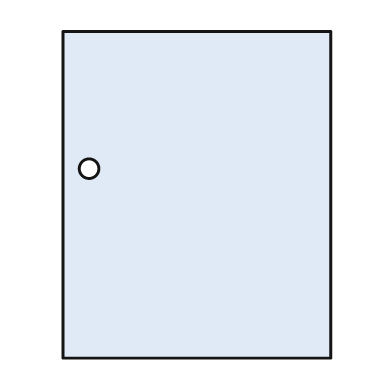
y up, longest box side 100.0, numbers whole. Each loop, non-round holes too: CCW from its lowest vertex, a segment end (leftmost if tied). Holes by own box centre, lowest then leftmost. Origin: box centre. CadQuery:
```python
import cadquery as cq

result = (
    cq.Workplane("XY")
    .moveTo(-41.0, -50.0)
    .lineTo(41.0, -50.0)
    .lineTo(41.0, 50.0)
    .lineTo(-41.0, 50.0)
    .close()
    .moveTo(-33.0, 8.0)
    .circle(3.0)
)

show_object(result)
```